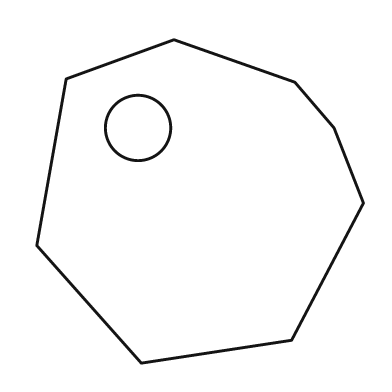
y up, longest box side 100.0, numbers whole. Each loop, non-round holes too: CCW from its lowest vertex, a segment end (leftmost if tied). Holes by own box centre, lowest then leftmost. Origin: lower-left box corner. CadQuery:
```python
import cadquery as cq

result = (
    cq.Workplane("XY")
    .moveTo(32.0, 0.0)
    .lineTo(78.0, 7.0)
    .lineTo(100.0, 49.0)
    .lineTo(91.0, 72.0)
    .lineTo(79.0, 86.0)
    .lineTo(42.0, 99.0)
    .lineTo(9.0, 87.0)
    .lineTo(0.0, 36.0)
    .close()
    .moveTo(31.0, 72.0)
    .circle(10.0)
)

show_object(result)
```